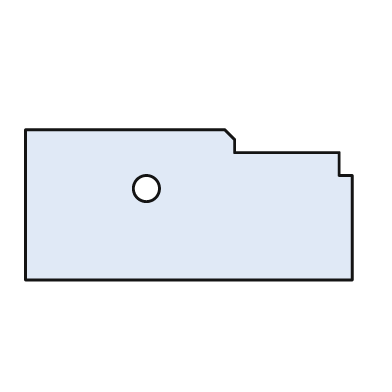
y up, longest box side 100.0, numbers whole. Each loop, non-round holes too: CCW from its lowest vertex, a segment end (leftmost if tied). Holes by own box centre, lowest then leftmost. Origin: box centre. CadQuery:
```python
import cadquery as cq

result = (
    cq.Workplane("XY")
    .moveTo(-50.0, -23.0)
    .lineTo(50.0, -23.0)
    .lineTo(50.0, 9.0)
    .lineTo(46.0, 9.0)
    .lineTo(46.0, 16.0)
    .lineTo(14.0, 16.0)
    .lineTo(14.0, 20.0)
    .lineTo(11.0, 23.0)
    .lineTo(-50.0, 23.0)
    .close()
    .moveTo(-13.0, 5.0)
    .circle(4.0)
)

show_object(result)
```